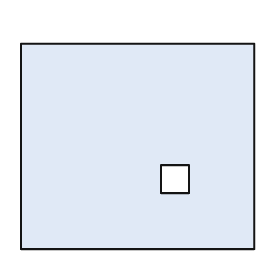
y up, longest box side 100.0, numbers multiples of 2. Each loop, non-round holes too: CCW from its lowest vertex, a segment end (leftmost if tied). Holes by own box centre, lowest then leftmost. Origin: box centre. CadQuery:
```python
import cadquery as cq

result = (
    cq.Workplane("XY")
    .moveTo(-50.0, -44.0)
    .lineTo(50.0, -44.0)
    .lineTo(50.0, 44.0)
    .lineTo(-50.0, 44.0)
    .close()
    .moveTo(10.0, -20.0)
    .lineTo(22.0, -20.0)
    .lineTo(22.0, -8.0)
    .lineTo(10.0, -8.0)
    .close()
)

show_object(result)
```